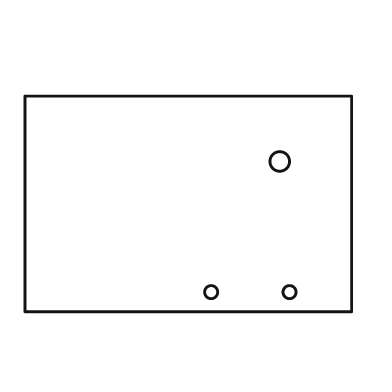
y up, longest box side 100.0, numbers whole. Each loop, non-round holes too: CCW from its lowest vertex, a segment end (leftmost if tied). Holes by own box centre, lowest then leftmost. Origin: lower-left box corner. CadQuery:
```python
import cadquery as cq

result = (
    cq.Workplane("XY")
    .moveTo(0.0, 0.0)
    .lineTo(100.0, 0.0)
    .lineTo(100.0, 66.0)
    .lineTo(0.0, 66.0)
    .close()
    .moveTo(57.0, 6.0)
    .circle(2.0)
    .moveTo(81.0, 6.0)
    .circle(2.0)
    .moveTo(78.0, 46.0)
    .circle(3.0)
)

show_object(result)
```